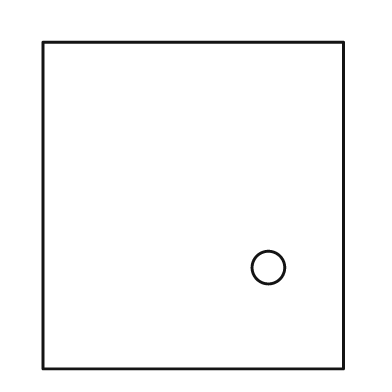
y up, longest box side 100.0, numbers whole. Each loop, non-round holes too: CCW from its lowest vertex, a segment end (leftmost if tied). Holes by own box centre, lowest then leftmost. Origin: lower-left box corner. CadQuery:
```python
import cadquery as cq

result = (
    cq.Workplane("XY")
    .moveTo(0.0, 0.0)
    .lineTo(92.0, 0.0)
    .lineTo(92.0, 100.0)
    .lineTo(0.0, 100.0)
    .close()
    .moveTo(69.0, 31.0)
    .circle(5.0)
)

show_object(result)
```